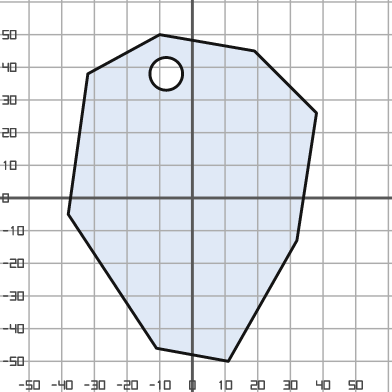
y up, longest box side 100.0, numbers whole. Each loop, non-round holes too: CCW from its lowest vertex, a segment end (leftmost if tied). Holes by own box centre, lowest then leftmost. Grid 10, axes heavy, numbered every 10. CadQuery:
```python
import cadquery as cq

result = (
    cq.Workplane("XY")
    .moveTo(11.0, -50.0)
    .lineTo(32.0, -13.0)
    .lineTo(38.0, 26.0)
    .lineTo(19.0, 45.0)
    .lineTo(-10.0, 50.0)
    .lineTo(-32.0, 38.0)
    .lineTo(-38.0, -5.0)
    .lineTo(-11.0, -46.0)
    .close()
    .moveTo(-8.0, 38.0)
    .circle(5.0)
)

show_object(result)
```